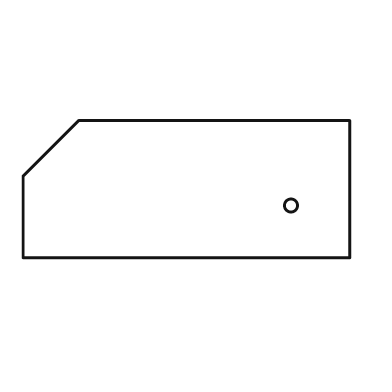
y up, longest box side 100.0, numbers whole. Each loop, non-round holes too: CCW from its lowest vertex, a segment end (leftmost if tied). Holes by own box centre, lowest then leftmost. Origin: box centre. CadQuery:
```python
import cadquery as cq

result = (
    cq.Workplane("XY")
    .moveTo(-50.0, -21.0)
    .lineTo(50.0, -21.0)
    .lineTo(50.0, 21.0)
    .lineTo(-33.0, 21.0)
    .lineTo(-50.0, 4.0)
    .close()
    .moveTo(32.0, -5.0)
    .circle(2.0)
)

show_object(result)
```